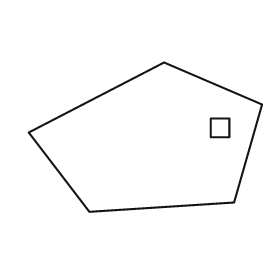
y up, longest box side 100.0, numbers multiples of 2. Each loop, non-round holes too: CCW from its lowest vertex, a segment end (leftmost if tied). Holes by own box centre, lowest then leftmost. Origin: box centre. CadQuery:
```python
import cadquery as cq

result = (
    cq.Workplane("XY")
    .moveTo(-24.0, -32.0)
    .lineTo(38.0, -28.0)
    .lineTo(50.0, 14.0)
    .lineTo(8.0, 32.0)
    .lineTo(-50.0, 2.0)
    .close()
    .moveTo(28.0, 0.0)
    .lineTo(36.0, 0.0)
    .lineTo(36.0, 8.0)
    .lineTo(28.0, 8.0)
    .close()
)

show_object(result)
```